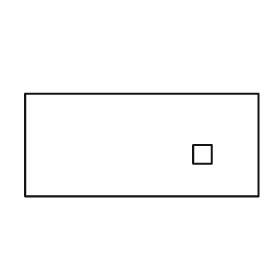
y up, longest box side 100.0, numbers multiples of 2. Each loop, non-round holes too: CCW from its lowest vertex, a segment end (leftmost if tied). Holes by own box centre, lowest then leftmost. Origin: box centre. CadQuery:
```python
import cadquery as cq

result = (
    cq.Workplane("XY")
    .moveTo(-50.0, -22.0)
    .lineTo(50.0, -22.0)
    .lineTo(50.0, 22.0)
    .lineTo(-50.0, 22.0)
    .close()
    .moveTo(22.0, -8.0)
    .lineTo(30.0, -8.0)
    .lineTo(30.0, 0.0)
    .lineTo(22.0, 0.0)
    .close()
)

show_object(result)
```